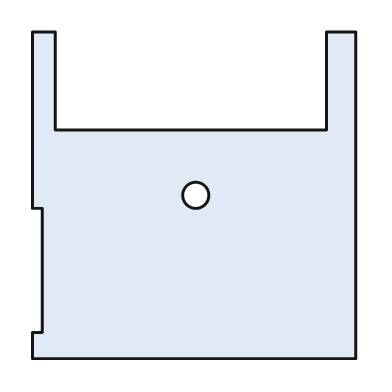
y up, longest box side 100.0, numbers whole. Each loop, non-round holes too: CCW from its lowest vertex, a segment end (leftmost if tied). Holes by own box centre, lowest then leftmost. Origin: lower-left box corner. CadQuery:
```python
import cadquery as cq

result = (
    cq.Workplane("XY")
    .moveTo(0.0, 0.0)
    .lineTo(99.0, 0.0)
    .lineTo(99.0, 100.0)
    .lineTo(90.0, 100.0)
    .lineTo(90.0, 70.0)
    .lineTo(7.0, 70.0)
    .lineTo(7.0, 100.0)
    .lineTo(0.0, 100.0)
    .lineTo(0.0, 46.0)
    .lineTo(3.0, 46.0)
    .lineTo(3.0, 8.0)
    .lineTo(0.0, 8.0)
    .close()
    .moveTo(50.0, 50.0)
    .circle(4.0)
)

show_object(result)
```